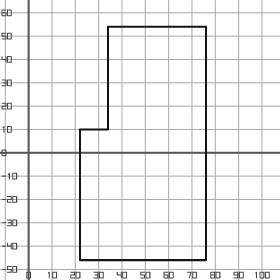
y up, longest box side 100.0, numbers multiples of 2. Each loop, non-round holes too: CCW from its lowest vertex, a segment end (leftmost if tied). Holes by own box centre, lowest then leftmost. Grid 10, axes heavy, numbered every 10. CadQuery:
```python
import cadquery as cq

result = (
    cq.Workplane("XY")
    .moveTo(22.0, -46.0)
    .lineTo(76.0, -46.0)
    .lineTo(76.0, 54.0)
    .lineTo(34.0, 54.0)
    .lineTo(34.0, 10.0)
    .lineTo(22.0, 10.0)
    .close()
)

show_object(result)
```